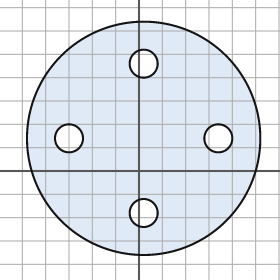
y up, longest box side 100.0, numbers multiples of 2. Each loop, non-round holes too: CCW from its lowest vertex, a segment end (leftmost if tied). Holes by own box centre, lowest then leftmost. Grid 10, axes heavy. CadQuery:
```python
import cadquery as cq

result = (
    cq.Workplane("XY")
    .moveTo(2.0, 14.0)
    .circle(50.0)
    .moveTo(2.0, -18.0)
    .circle(6.0)
    .moveTo(-30.0, 14.0)
    .circle(6.0)
    .moveTo(34.0, 14.0)
    .circle(6.0)
    .moveTo(2.0, 46.0)
    .circle(6.0)
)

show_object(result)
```